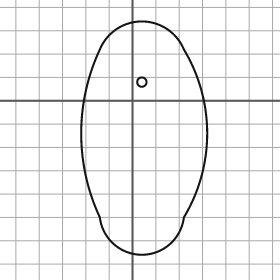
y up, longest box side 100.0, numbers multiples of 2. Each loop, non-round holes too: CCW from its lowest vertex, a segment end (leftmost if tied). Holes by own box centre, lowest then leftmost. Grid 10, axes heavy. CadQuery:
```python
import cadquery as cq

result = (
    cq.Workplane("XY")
    .moveTo(-14.0, -50.0)
    .threePointArc((4.0, -66.0), (22.0, -50.0))
    .threePointArc((32.0, -14.0), (22.0, 22.0))
    .threePointArc((4.0, 34.0), (-14.0, 22.0))
    .threePointArc((-22.0, -14.0), (-14.0, -50.0))
    .close()
    .moveTo(4.0, 8.0)
    .circle(2.0)
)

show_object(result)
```